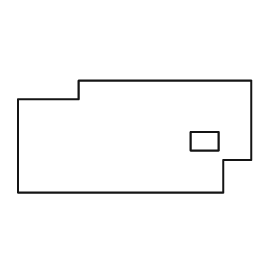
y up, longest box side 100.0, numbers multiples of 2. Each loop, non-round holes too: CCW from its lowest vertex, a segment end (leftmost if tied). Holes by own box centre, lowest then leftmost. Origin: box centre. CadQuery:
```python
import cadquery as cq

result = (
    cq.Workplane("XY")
    .moveTo(-50.0, -24.0)
    .lineTo(38.0, -24.0)
    .lineTo(38.0, -10.0)
    .lineTo(50.0, -10.0)
    .lineTo(50.0, 24.0)
    .lineTo(-24.0, 24.0)
    .lineTo(-24.0, 16.0)
    .lineTo(-50.0, 16.0)
    .close()
    .moveTo(24.0, -6.0)
    .lineTo(36.0, -6.0)
    .lineTo(36.0, 2.0)
    .lineTo(24.0, 2.0)
    .close()
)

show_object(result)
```